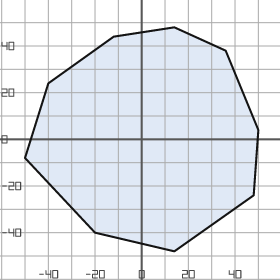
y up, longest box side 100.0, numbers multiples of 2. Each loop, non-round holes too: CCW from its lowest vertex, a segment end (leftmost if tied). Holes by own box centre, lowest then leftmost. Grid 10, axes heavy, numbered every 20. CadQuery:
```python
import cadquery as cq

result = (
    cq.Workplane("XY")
    .moveTo(14.0, -48.0)
    .lineTo(48.0, -24.0)
    .lineTo(50.0, 4.0)
    .lineTo(36.0, 38.0)
    .lineTo(14.0, 48.0)
    .lineTo(-12.0, 44.0)
    .lineTo(-40.0, 24.0)
    .lineTo(-50.0, -8.0)
    .lineTo(-20.0, -40.0)
    .close()
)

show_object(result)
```